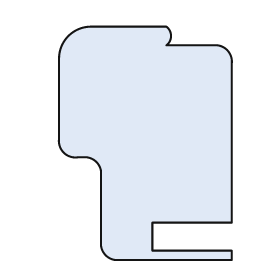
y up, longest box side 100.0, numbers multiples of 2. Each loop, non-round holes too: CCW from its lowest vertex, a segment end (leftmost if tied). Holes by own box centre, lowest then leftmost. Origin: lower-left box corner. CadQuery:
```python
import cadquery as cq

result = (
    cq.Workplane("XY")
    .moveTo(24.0, 0.0)
    .lineTo(74.0, 0.0)
    .lineTo(74.0, 4.0)
    .lineTo(40.0, 4.0)
    .lineTo(40.0, 16.0)
    .lineTo(74.0, 16.0)
    .lineTo(74.0, 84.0)
    .threePointArc((72.0, 90.0), (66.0, 92.0))
    .lineTo(46.0, 92.0)
    .threePointArc((48.0, 96.0), (46.0, 100.0))
    .lineTo(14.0, 100.0)
    .threePointArc((4.0, 96.0), (0.0, 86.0))
    .lineTo(0.0, 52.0)
    .threePointArc((2.0, 46.0), (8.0, 44.0))
    .lineTo(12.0, 44.0)
    .threePointArc((16.0, 42.0), (18.0, 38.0))
    .lineTo(18.0, 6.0)
    .threePointArc((20.0, 2.0), (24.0, 0.0))
    .close()
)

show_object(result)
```